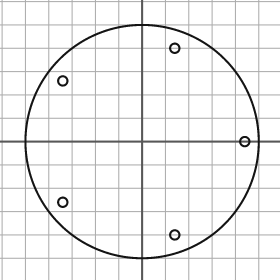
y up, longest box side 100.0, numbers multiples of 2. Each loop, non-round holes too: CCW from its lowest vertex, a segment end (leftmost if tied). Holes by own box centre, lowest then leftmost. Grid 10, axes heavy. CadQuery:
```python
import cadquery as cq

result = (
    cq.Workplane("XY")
    .moveTo(0.0, 0.0)
    .circle(50.0)
    .moveTo(14.0, -40.0)
    .circle(2.0)
    .moveTo(-34.0, -26.0)
    .circle(2.0)
    .moveTo(44.0, 0.0)
    .circle(2.0)
    .moveTo(-34.0, 26.0)
    .circle(2.0)
    .moveTo(14.0, 40.0)
    .circle(2.0)
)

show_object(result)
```